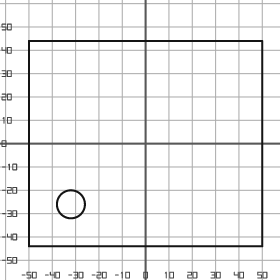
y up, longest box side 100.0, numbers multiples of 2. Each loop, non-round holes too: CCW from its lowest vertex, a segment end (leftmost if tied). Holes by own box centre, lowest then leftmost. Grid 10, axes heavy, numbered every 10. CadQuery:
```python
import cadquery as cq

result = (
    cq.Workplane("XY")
    .moveTo(-50.0, -44.0)
    .lineTo(50.0, -44.0)
    .lineTo(50.0, 44.0)
    .lineTo(-50.0, 44.0)
    .close()
    .moveTo(-32.0, -26.0)
    .circle(6.0)
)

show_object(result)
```